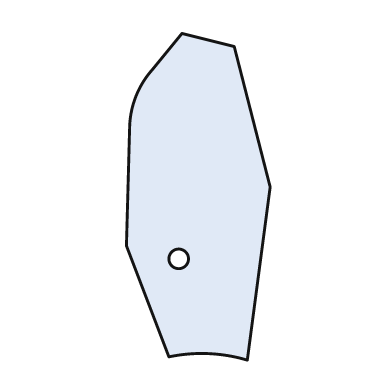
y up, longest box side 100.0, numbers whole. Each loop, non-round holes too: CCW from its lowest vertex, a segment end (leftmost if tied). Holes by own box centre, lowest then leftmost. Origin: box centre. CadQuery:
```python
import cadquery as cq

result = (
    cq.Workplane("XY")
    .moveTo(15.0, -50.0)
    .lineTo(22.0, 3.0)
    .lineTo(11.0, 46.0)
    .lineTo(-5.0, 50.0)
    .lineTo(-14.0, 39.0)
    .threePointArc((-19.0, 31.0), (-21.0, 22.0))
    .lineTo(-22.0, -15.0)
    .lineTo(-9.0, -49.0)
    .threePointArc((3.0, -48.0), (15.0, -50.0))
    .close()
    .moveTo(-6.0, -19.0)
    .circle(3.0)
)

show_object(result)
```